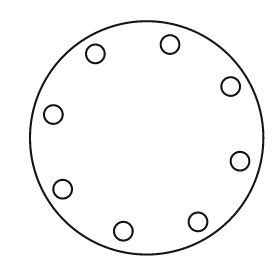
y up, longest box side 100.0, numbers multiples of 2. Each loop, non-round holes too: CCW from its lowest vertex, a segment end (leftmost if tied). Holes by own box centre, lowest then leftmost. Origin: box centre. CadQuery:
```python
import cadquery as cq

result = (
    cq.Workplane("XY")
    .moveTo(0.0, 0.0)
    .circle(50.0)
    .moveTo(-10.0, -40.0)
    .circle(4.0)
    .moveTo(22.0, -36.0)
    .circle(4.0)
    .moveTo(-36.0, -22.0)
    .circle(4.0)
    .moveTo(40.0, -10.0)
    .circle(4.0)
    .moveTo(-40.0, 10.0)
    .circle(4.0)
    .moveTo(36.0, 22.0)
    .circle(4.0)
    .moveTo(-22.0, 36.0)
    .circle(4.0)
    .moveTo(10.0, 40.0)
    .circle(4.0)
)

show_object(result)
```